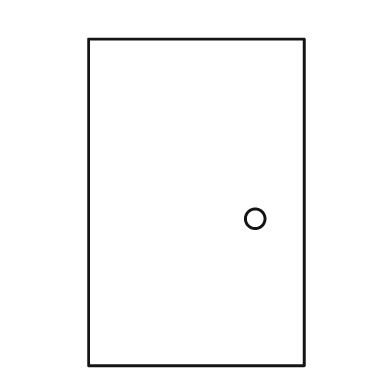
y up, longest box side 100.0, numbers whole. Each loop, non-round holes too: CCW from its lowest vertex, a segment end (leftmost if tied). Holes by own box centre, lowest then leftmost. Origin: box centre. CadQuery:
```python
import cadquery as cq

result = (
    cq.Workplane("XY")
    .moveTo(-33.0, -50.0)
    .lineTo(33.0, -50.0)
    .lineTo(33.0, 50.0)
    .lineTo(-33.0, 50.0)
    .close()
    .moveTo(18.0, -5.0)
    .circle(3.0)
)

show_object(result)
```